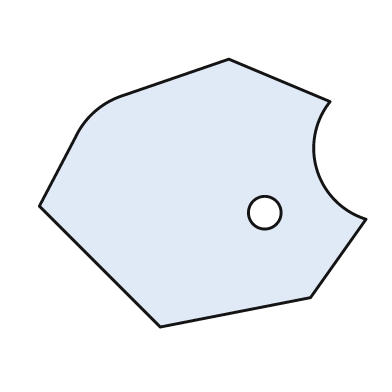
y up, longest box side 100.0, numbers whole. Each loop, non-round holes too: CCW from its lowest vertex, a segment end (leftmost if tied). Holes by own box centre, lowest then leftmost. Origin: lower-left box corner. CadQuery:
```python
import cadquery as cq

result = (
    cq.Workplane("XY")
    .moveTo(37.0, 0.0)
    .lineTo(83.0, 9.0)
    .lineTo(100.0, 33.0)
    .threePointArc((85.0, 48.0), (89.0, 69.0))
    .lineTo(58.0, 82.0)
    .lineTo(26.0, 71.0)
    .threePointArc((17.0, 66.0), (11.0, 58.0))
    .lineTo(0.0, 37.0)
    .close()
    .moveTo(69.0, 35.0)
    .circle(5.0)
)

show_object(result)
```